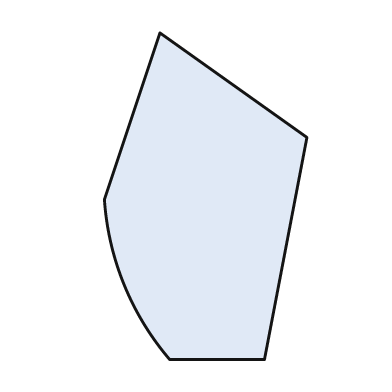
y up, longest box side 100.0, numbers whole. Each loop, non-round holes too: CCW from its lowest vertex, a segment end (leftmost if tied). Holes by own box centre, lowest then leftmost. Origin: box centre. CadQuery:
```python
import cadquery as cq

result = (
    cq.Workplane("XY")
    .moveTo(-11.0, -50.0)
    .lineTo(18.0, -50.0)
    .lineTo(31.0, 18.0)
    .lineTo(-14.0, 50.0)
    .lineTo(-31.0, -1.0)
    .threePointArc((-25.0, -27.0), (-11.0, -50.0))
    .close()
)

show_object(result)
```